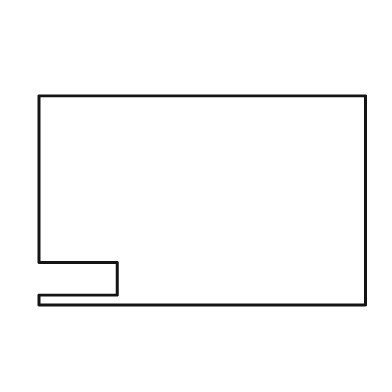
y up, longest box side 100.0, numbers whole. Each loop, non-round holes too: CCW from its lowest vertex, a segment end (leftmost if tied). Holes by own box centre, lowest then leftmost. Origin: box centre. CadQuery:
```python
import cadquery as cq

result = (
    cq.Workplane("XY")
    .moveTo(-50.0, -32.0)
    .lineTo(50.0, -32.0)
    .lineTo(50.0, 32.0)
    .lineTo(-50.0, 32.0)
    .lineTo(-50.0, -19.0)
    .lineTo(-26.0, -19.0)
    .lineTo(-26.0, -29.0)
    .lineTo(-50.0, -29.0)
    .close()
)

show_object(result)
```